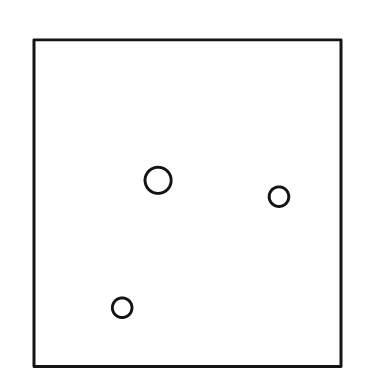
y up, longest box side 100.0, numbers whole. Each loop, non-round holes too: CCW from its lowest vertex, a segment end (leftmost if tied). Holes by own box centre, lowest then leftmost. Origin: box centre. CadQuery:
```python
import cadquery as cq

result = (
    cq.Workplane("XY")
    .moveTo(-47.0, -50.0)
    .lineTo(47.0, -50.0)
    .lineTo(47.0, 50.0)
    .lineTo(-47.0, 50.0)
    .close()
    .moveTo(-20.0, -32.0)
    .circle(3.0)
    .moveTo(28.0, 2.0)
    .circle(3.0)
    .moveTo(-9.0, 7.0)
    .circle(4.0)
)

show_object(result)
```